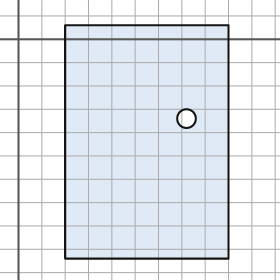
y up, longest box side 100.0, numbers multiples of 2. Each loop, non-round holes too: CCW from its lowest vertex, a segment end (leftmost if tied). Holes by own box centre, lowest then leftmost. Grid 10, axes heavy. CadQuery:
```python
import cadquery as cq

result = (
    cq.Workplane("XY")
    .moveTo(20.0, -94.0)
    .lineTo(90.0, -94.0)
    .lineTo(90.0, 6.0)
    .lineTo(20.0, 6.0)
    .close()
    .moveTo(72.0, -34.0)
    .circle(4.0)
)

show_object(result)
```